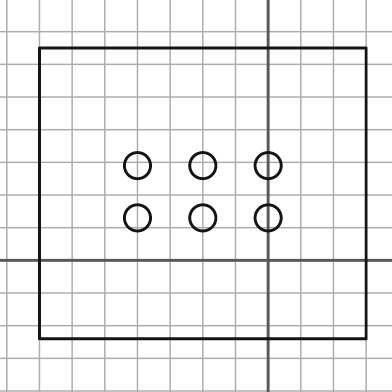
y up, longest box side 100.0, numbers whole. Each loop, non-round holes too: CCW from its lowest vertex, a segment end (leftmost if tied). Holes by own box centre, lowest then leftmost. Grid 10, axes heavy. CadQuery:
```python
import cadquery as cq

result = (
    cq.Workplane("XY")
    .moveTo(-70.0, -24.0)
    .lineTo(30.0, -24.0)
    .lineTo(30.0, 65.0)
    .lineTo(-70.0, 65.0)
    .close()
    .moveTo(-40.0, 13.0)
    .circle(4.0)
    .moveTo(-20.0, 13.0)
    .circle(4.0)
    .moveTo(0.0, 13.0)
    .circle(4.0)
    .moveTo(-40.0, 29.0)
    .circle(4.0)
    .moveTo(-20.0, 29.0)
    .circle(4.0)
    .moveTo(0.0, 29.0)
    .circle(4.0)
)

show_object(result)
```